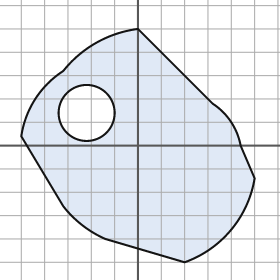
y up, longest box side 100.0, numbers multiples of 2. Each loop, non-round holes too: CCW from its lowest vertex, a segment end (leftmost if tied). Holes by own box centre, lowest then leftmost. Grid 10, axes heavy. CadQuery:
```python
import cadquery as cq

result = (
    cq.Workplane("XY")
    .moveTo(20.0, -50.0)
    .threePointArc((40.0, -36.0), (50.0, -14.0))
    .lineTo(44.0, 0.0)
    .threePointArc((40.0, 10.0), (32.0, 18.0))
    .lineTo(0.0, 50.0)
    .threePointArc((-18.0, 44.0), (-32.0, 32.0))
    .threePointArc((-44.0, 20.0), (-50.0, 4.0))
    .lineTo(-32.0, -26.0)
    .threePointArc((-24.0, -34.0), (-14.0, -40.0))
    .close()
    .moveTo(-22.0, 14.0)
    .circle(12.0)
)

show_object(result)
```